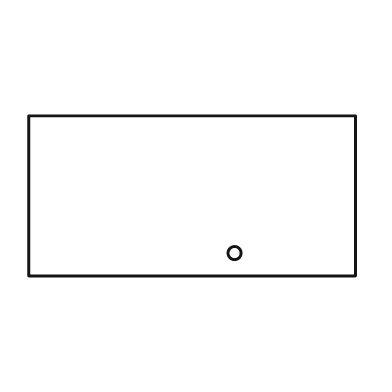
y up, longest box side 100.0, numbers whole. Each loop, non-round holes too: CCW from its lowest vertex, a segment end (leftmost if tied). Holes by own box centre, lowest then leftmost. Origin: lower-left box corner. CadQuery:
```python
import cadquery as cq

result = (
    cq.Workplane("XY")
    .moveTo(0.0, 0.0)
    .lineTo(100.0, 0.0)
    .lineTo(100.0, 49.0)
    .lineTo(0.0, 49.0)
    .close()
    .moveTo(63.0, 7.0)
    .circle(2.0)
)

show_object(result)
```